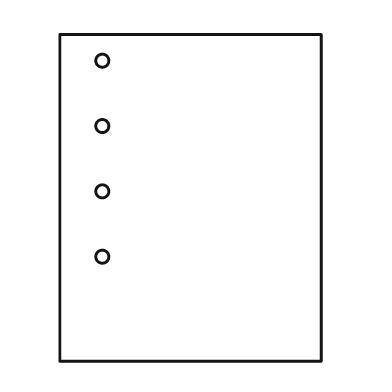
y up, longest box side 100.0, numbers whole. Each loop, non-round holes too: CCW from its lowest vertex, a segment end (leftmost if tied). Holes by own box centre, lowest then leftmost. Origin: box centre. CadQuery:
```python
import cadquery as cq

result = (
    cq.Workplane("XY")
    .moveTo(-40.0, -50.0)
    .lineTo(40.0, -50.0)
    .lineTo(40.0, 50.0)
    .lineTo(-40.0, 50.0)
    .close()
    .moveTo(-27.0, -18.0)
    .circle(2.0)
    .moveTo(-27.0, 2.0)
    .circle(2.0)
    .moveTo(-27.0, 22.0)
    .circle(2.0)
    .moveTo(-27.0, 42.0)
    .circle(2.0)
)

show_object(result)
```